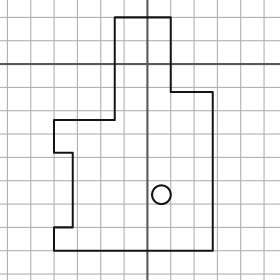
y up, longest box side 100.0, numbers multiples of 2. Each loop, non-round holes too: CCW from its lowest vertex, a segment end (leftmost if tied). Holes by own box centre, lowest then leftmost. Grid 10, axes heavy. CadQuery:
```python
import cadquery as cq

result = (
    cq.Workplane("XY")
    .moveTo(-40.0, -80.0)
    .lineTo(28.0, -80.0)
    .lineTo(28.0, -12.0)
    .lineTo(10.0, -12.0)
    .lineTo(10.0, 20.0)
    .lineTo(-14.0, 20.0)
    .lineTo(-14.0, -24.0)
    .lineTo(-40.0, -24.0)
    .lineTo(-40.0, -38.0)
    .lineTo(-32.0, -38.0)
    .lineTo(-32.0, -70.0)
    .lineTo(-40.0, -70.0)
    .close()
    .moveTo(6.0, -56.0)
    .circle(4.0)
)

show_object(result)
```